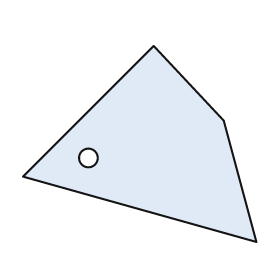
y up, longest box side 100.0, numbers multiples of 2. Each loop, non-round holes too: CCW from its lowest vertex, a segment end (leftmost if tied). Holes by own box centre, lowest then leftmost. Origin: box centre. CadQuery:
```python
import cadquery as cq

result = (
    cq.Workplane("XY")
    .moveTo(50.0, -42.0)
    .lineTo(36.0, 10.0)
    .lineTo(6.0, 42.0)
    .lineTo(-50.0, -14.0)
    .close()
    .moveTo(-22.0, -6.0)
    .circle(4.0)
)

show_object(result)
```